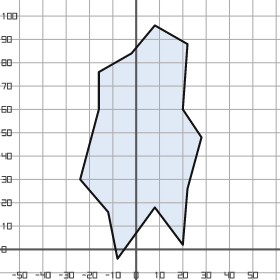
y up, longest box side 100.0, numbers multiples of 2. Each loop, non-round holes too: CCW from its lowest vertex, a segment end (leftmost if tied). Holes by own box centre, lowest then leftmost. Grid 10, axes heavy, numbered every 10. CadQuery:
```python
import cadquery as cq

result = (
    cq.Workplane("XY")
    .moveTo(-8.0, -4.0)
    .lineTo(8.0, 18.0)
    .lineTo(20.0, 2.0)
    .lineTo(22.0, 26.0)
    .lineTo(28.0, 48.0)
    .lineTo(20.0, 60.0)
    .lineTo(22.0, 88.0)
    .lineTo(8.0, 96.0)
    .lineTo(-2.0, 84.0)
    .lineTo(-16.0, 76.0)
    .lineTo(-16.0, 60.0)
    .lineTo(-24.0, 30.0)
    .lineTo(-12.0, 16.0)
    .close()
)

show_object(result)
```